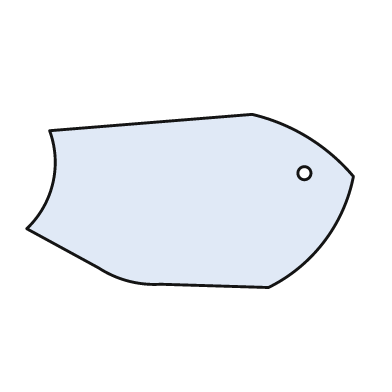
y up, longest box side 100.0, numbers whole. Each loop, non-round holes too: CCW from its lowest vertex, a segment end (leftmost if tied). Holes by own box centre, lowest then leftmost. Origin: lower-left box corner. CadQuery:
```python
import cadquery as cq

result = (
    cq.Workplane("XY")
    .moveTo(74.0, 0.0)
    .threePointArc((91.0, 14.0), (100.0, 34.0))
    .threePointArc((86.0, 46.0), (69.0, 53.0))
    .lineTo(7.0, 48.0)
    .threePointArc((8.0, 32.0), (0.0, 18.0))
    .lineTo(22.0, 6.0)
    .threePointArc((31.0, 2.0), (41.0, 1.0))
    .close()
    .moveTo(85.0, 35.0)
    .circle(2.0)
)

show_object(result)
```